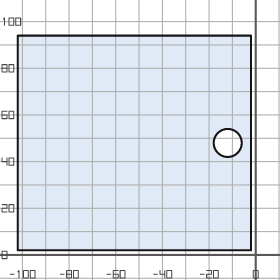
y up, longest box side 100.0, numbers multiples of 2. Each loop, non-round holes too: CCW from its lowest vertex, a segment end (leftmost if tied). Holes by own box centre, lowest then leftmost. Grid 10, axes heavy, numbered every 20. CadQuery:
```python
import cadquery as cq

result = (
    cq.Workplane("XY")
    .moveTo(-102.0, 2.0)
    .lineTo(-2.0, 2.0)
    .lineTo(-2.0, 94.0)
    .lineTo(-102.0, 94.0)
    .close()
    .moveTo(-12.0, 48.0)
    .circle(6.0)
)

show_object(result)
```